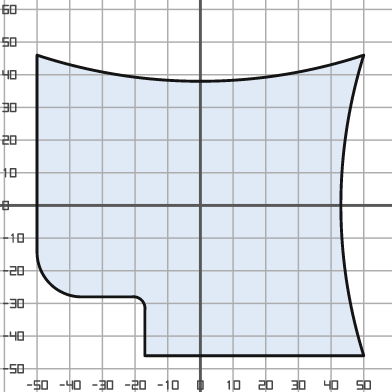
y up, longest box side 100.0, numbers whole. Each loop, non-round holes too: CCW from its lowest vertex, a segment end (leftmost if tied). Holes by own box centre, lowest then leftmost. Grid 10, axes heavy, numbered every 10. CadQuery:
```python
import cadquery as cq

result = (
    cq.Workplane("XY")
    .moveTo(-17.0, -46.0)
    .lineTo(50.0, -46.0)
    .threePointArc((43.0, 0.0), (50.0, 46.0))
    .threePointArc((0.0, 38.0), (-50.0, 46.0))
    .lineTo(-50.0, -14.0)
    .threePointArc((-46.0, -24.0), (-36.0, -28.0))
    .lineTo(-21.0, -28.0)
    .threePointArc((-18.0, -29.0), (-17.0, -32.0))
    .close()
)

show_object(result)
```